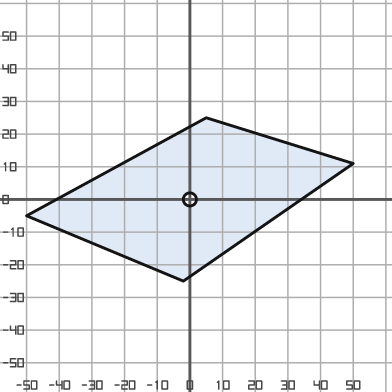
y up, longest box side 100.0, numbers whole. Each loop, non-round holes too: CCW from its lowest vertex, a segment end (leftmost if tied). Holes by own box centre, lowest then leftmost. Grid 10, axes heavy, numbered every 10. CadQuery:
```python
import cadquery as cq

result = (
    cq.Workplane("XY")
    .moveTo(-2.0, -25.0)
    .lineTo(50.0, 11.0)
    .lineTo(5.0, 25.0)
    .lineTo(-50.0, -5.0)
    .close()
    .moveTo(0.0, 0.0)
    .circle(2.0)
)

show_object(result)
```